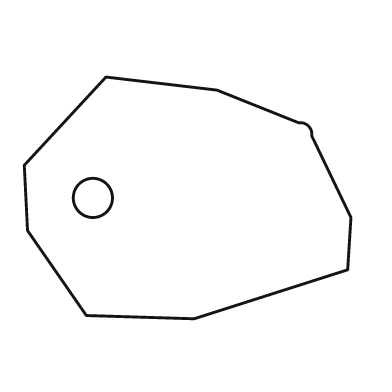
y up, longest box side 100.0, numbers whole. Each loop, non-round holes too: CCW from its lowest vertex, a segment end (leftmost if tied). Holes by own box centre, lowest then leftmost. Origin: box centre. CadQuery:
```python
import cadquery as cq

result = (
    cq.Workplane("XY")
    .moveTo(2.0, -37.0)
    .lineTo(49.0, -22.0)
    .lineTo(50.0, -6.0)
    .lineTo(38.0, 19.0)
    .threePointArc((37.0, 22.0), (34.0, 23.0))
    .lineTo(9.0, 33.0)
    .lineTo(-25.0, 37.0)
    .lineTo(-50.0, 10.0)
    .lineTo(-49.0, -10.0)
    .lineTo(-31.0, -36.0)
    .close()
    .moveTo(-29.0, 0.0)
    .circle(6.0)
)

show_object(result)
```